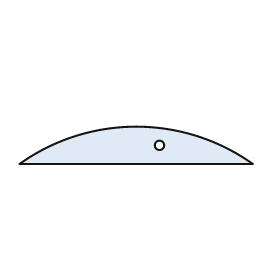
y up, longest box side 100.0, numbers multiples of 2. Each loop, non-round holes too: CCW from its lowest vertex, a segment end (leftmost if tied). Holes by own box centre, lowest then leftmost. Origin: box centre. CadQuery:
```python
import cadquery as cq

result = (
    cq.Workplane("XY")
    .moveTo(-50.0, -8.0)
    .lineTo(50.0, -8.0)
    .threePointArc((0.0, 8.0), (-50.0, -8.0))
    .close()
    .moveTo(10.0, 0.0)
    .circle(2.0)
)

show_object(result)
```